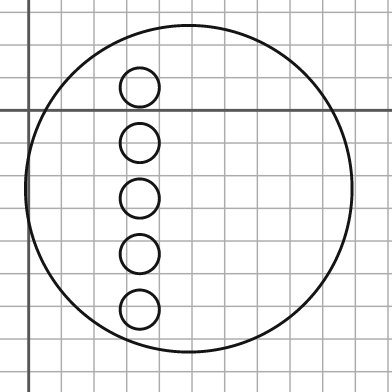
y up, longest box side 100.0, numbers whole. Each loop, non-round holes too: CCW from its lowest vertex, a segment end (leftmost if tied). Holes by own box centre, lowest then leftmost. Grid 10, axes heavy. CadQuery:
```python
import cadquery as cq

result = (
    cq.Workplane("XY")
    .moveTo(49.0, -24.0)
    .circle(50.0)
    .moveTo(34.0, -61.0)
    .circle(6.0)
    .moveTo(34.0, -44.0)
    .circle(6.0)
    .moveTo(34.0, -27.0)
    .circle(6.0)
    .moveTo(34.0, -10.0)
    .circle(6.0)
    .moveTo(34.0, 7.0)
    .circle(6.0)
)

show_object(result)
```